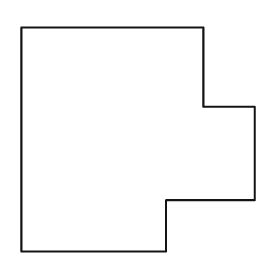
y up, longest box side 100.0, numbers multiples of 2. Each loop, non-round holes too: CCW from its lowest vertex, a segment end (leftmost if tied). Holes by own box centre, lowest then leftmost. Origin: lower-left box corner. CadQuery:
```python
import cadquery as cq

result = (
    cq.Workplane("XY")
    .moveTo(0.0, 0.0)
    .lineTo(62.0, 0.0)
    .lineTo(62.0, 22.0)
    .lineTo(100.0, 22.0)
    .lineTo(100.0, 62.0)
    .lineTo(78.0, 62.0)
    .lineTo(78.0, 96.0)
    .lineTo(0.0, 96.0)
    .close()
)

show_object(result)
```